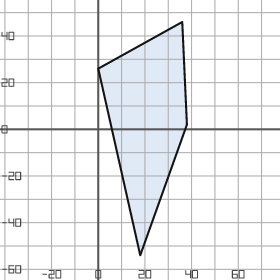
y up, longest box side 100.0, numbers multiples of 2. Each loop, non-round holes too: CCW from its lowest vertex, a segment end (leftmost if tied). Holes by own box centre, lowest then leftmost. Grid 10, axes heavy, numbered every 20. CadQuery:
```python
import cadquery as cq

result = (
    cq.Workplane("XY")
    .moveTo(18.0, -54.0)
    .lineTo(38.0, 2.0)
    .lineTo(36.0, 46.0)
    .lineTo(0.0, 26.0)
    .close()
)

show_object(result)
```